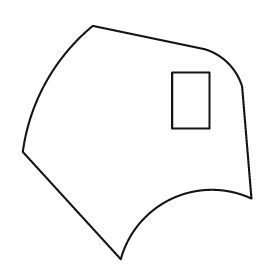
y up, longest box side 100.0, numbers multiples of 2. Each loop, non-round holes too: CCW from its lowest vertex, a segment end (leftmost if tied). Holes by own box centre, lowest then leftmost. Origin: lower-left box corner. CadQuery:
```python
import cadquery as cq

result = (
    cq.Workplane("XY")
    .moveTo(42.0, 0.0)
    .threePointArc((64.0, 26.0), (98.0, 26.0))
    .lineTo(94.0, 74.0)
    .threePointArc((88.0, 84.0), (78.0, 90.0))
    .lineTo(30.0, 100.0)
    .threePointArc((10.0, 76.0), (0.0, 46.0))
    .close()
    .moveTo(64.0, 56.0)
    .lineTo(80.0, 56.0)
    .lineTo(80.0, 80.0)
    .lineTo(64.0, 80.0)
    .close()
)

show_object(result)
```